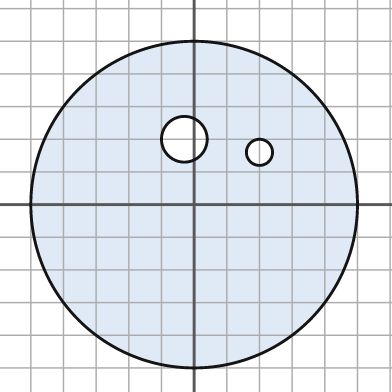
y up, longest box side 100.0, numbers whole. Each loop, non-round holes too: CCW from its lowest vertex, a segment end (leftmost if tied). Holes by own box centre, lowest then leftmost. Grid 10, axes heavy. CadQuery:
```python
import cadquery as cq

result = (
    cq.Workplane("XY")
    .moveTo(0.0, 0.0)
    .circle(50.0)
    .moveTo(20.0, 16.0)
    .circle(4.0)
    .moveTo(-3.0, 20.0)
    .circle(7.0)
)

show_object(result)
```